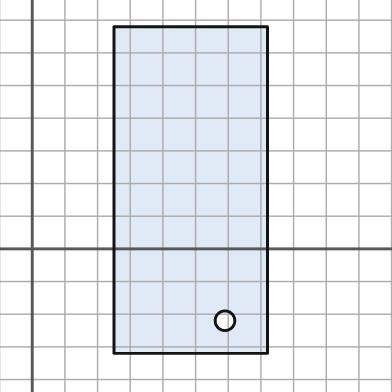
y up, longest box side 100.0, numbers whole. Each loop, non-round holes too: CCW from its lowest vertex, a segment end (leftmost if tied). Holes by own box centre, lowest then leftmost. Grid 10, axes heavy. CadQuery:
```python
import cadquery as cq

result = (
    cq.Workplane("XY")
    .moveTo(25.0, -32.0)
    .lineTo(72.0, -32.0)
    .lineTo(72.0, 68.0)
    .lineTo(25.0, 68.0)
    .close()
    .moveTo(59.0, -22.0)
    .circle(3.0)
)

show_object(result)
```